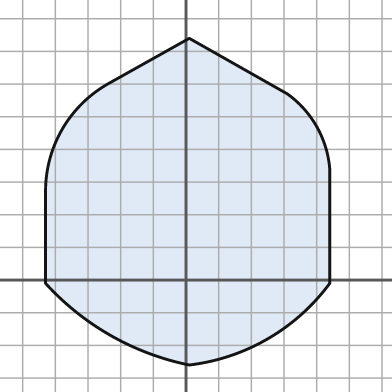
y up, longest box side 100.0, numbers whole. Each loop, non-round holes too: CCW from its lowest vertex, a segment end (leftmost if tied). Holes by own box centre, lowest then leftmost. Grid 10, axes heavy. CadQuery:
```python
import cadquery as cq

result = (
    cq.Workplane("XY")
    .moveTo(1.0, -26.0)
    .threePointArc((25.0, -18.0), (44.0, -1.0))
    .lineTo(44.0, 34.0)
    .threePointArc((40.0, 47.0), (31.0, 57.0))
    .lineTo(1.0, 74.0)
    .lineTo(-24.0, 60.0)
    .threePointArc((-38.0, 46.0), (-43.0, 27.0))
    .lineTo(-43.0, -1.0)
    .threePointArc((-23.0, -17.0), (1.0, -26.0))
    .close()
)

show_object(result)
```